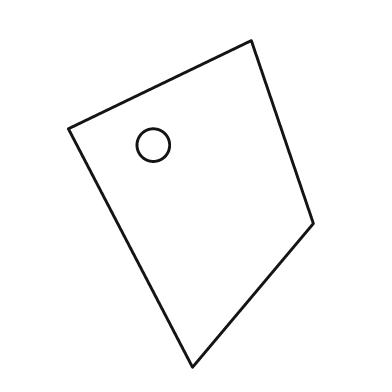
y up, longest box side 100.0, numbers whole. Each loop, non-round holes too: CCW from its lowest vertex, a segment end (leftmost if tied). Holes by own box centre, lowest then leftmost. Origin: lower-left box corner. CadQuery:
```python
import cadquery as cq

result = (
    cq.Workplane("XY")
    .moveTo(38.0, 0.0)
    .lineTo(75.0, 44.0)
    .lineTo(56.0, 100.0)
    .lineTo(0.0, 73.0)
    .close()
    .moveTo(26.0, 68.0)
    .circle(5.0)
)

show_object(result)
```